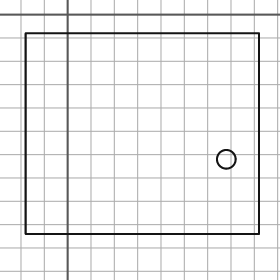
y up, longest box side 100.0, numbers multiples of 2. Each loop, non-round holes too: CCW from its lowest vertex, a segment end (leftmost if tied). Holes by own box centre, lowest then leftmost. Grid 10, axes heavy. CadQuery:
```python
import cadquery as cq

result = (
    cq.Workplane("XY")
    .moveTo(-18.0, -94.0)
    .lineTo(82.0, -94.0)
    .lineTo(82.0, -8.0)
    .lineTo(-18.0, -8.0)
    .close()
    .moveTo(68.0, -62.0)
    .circle(4.0)
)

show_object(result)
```